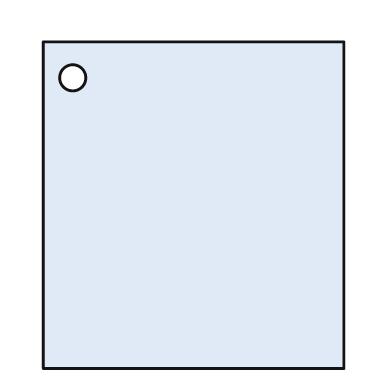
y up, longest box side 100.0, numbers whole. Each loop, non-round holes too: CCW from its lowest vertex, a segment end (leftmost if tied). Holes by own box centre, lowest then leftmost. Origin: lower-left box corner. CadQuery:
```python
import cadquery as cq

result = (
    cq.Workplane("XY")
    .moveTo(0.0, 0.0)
    .lineTo(92.0, 0.0)
    .lineTo(92.0, 100.0)
    .lineTo(0.0, 100.0)
    .close()
    .moveTo(9.0, 89.0)
    .circle(4.0)
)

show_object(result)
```